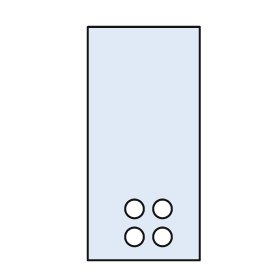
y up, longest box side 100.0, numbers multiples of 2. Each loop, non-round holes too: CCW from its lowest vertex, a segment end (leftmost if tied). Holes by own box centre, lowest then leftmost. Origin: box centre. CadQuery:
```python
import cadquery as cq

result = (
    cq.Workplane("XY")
    .moveTo(-24.0, -50.0)
    .lineTo(24.0, -50.0)
    .lineTo(24.0, 50.0)
    .lineTo(-24.0, 50.0)
    .close()
    .moveTo(-4.0, -40.0)
    .circle(4.0)
    .moveTo(8.0, -40.0)
    .circle(4.0)
    .moveTo(-4.0, -28.0)
    .circle(4.0)
    .moveTo(8.0, -28.0)
    .circle(4.0)
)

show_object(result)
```